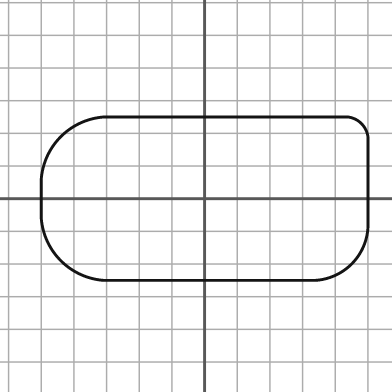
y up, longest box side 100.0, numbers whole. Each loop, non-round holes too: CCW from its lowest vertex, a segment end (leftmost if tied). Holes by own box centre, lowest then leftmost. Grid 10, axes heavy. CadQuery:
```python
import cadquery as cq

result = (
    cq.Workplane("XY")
    .moveTo(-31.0, -25.0)
    .lineTo(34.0, -25.0)
    .threePointArc((45.0, -20.0), (50.0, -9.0))
    .lineTo(50.0, 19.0)
    .threePointArc((48.0, 23.0), (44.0, 25.0))
    .lineTo(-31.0, 25.0)
    .threePointArc((-44.0, 19.0), (-50.0, 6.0))
    .lineTo(-50.0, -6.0)
    .threePointArc((-44.0, -19.0), (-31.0, -25.0))
    .close()
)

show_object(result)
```